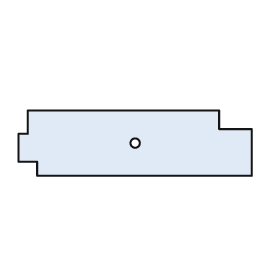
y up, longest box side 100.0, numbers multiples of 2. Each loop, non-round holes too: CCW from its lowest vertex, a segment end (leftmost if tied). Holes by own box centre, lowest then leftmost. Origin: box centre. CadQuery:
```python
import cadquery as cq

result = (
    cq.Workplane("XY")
    .moveTo(-42.0, -14.0)
    .lineTo(50.0, -14.0)
    .lineTo(50.0, 6.0)
    .lineTo(36.0, 6.0)
    .lineTo(36.0, 14.0)
    .lineTo(-46.0, 14.0)
    .lineTo(-46.0, 4.0)
    .lineTo(-50.0, 4.0)
    .lineTo(-50.0, -8.0)
    .lineTo(-42.0, -8.0)
    .close()
    .moveTo(0.0, 0.0)
    .circle(2.0)
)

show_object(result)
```